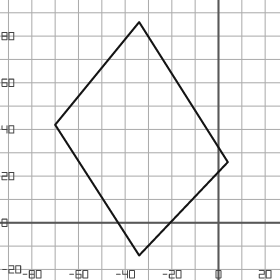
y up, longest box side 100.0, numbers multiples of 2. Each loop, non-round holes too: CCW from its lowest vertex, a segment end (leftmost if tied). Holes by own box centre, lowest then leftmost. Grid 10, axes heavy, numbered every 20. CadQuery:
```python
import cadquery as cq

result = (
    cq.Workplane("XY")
    .moveTo(-34.0, -14.0)
    .lineTo(4.0, 26.0)
    .lineTo(-34.0, 86.0)
    .lineTo(-70.0, 42.0)
    .close()
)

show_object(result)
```